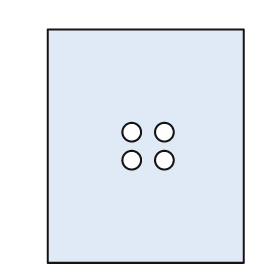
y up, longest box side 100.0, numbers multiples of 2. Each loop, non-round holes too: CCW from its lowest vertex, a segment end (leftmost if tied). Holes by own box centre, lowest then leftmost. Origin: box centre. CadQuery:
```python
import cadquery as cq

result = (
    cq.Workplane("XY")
    .moveTo(-42.0, -50.0)
    .lineTo(42.0, -50.0)
    .lineTo(42.0, 50.0)
    .lineTo(-42.0, 50.0)
    .close()
    .moveTo(-6.0, -6.0)
    .circle(4.0)
    .moveTo(8.0, -6.0)
    .circle(4.0)
    .moveTo(-6.0, 6.0)
    .circle(4.0)
    .moveTo(8.0, 6.0)
    .circle(4.0)
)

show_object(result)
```